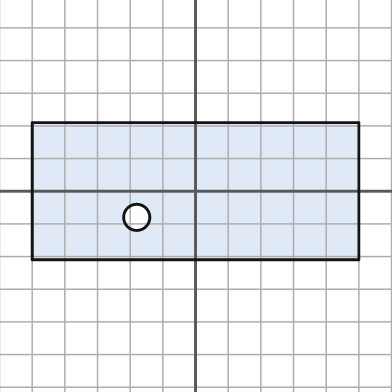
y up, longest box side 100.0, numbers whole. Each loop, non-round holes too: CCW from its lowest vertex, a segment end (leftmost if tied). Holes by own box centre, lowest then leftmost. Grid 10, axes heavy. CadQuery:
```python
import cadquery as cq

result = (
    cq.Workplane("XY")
    .moveTo(-50.0, -21.0)
    .lineTo(50.0, -21.0)
    .lineTo(50.0, 21.0)
    .lineTo(-50.0, 21.0)
    .close()
    .moveTo(-18.0, -8.0)
    .circle(4.0)
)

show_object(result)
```